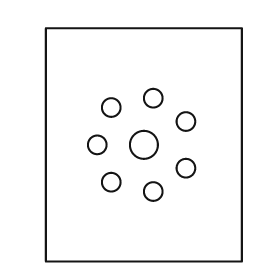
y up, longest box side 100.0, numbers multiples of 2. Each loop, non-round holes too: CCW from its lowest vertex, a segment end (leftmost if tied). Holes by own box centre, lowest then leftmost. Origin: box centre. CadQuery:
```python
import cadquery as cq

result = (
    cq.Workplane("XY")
    .moveTo(-42.0, -50.0)
    .lineTo(42.0, -50.0)
    .lineTo(42.0, 50.0)
    .lineTo(-42.0, 50.0)
    .close()
    .moveTo(4.0, -20.0)
    .circle(4.0)
    .moveTo(-14.0, -16.0)
    .circle(4.0)
    .moveTo(18.0, -10.0)
    .circle(4.0)
    .moveTo(-20.0, 0.0)
    .circle(4.0)
    .moveTo(0.0, 0.0)
    .circle(6.0)
    .moveTo(18.0, 10.0)
    .circle(4.0)
    .moveTo(-14.0, 16.0)
    .circle(4.0)
    .moveTo(4.0, 20.0)
    .circle(4.0)
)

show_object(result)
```